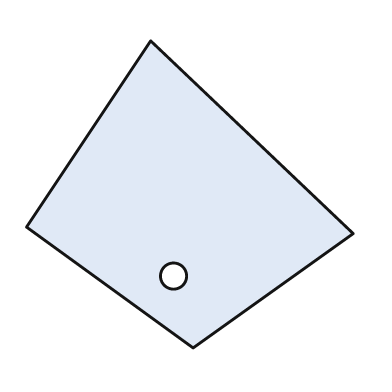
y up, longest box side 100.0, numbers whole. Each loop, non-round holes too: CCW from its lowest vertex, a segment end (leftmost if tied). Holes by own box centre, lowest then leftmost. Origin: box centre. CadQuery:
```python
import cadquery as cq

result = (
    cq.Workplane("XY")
    .moveTo(1.0, -47.0)
    .lineTo(50.0, -12.0)
    .lineTo(-12.0, 47.0)
    .lineTo(-50.0, -10.0)
    .close()
    .moveTo(-5.0, -25.0)
    .circle(4.0)
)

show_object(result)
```